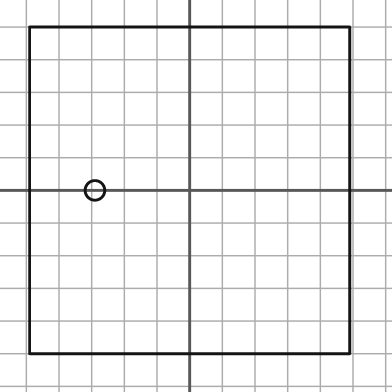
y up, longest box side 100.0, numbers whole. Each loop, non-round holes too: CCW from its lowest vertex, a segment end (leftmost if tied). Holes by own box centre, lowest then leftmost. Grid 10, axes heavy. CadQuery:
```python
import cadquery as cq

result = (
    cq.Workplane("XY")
    .moveTo(-49.0, -50.0)
    .lineTo(49.0, -50.0)
    .lineTo(49.0, 50.0)
    .lineTo(-49.0, 50.0)
    .close()
    .moveTo(-29.0, 0.0)
    .circle(3.0)
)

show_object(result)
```